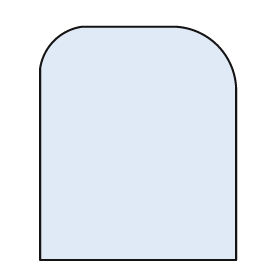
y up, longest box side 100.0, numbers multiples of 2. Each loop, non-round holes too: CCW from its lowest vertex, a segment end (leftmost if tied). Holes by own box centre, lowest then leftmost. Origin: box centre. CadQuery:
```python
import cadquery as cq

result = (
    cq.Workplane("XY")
    .moveTo(-42.0, -50.0)
    .lineTo(42.0, -50.0)
    .lineTo(42.0, 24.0)
    .threePointArc((34.0, 42.0), (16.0, 50.0))
    .lineTo(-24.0, 50.0)
    .threePointArc((-36.0, 44.0), (-42.0, 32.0))
    .close()
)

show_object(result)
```